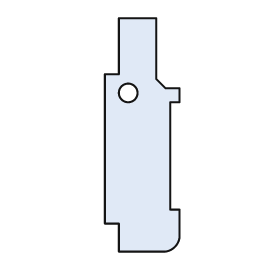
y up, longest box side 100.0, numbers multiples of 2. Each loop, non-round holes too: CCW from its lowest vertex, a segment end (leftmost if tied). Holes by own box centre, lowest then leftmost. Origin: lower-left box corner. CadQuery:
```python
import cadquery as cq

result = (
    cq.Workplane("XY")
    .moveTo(6.0, 0.0)
    .lineTo(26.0, 0.0)
    .threePointArc((30.0, 2.0), (32.0, 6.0))
    .lineTo(32.0, 18.0)
    .lineTo(28.0, 18.0)
    .lineTo(28.0, 64.0)
    .lineTo(32.0, 64.0)
    .lineTo(32.0, 70.0)
    .lineTo(26.0, 70.0)
    .lineTo(22.0, 74.0)
    .lineTo(22.0, 100.0)
    .lineTo(6.0, 100.0)
    .lineTo(6.0, 76.0)
    .lineTo(0.0, 76.0)
    .lineTo(0.0, 12.0)
    .lineTo(6.0, 12.0)
    .close()
    .moveTo(10.0, 68.0)
    .circle(4.0)
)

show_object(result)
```